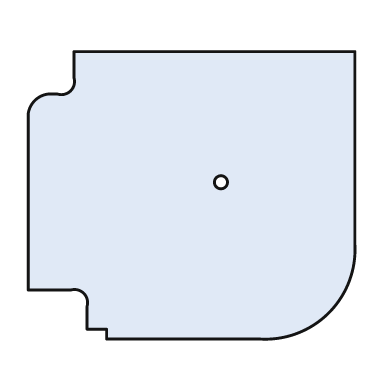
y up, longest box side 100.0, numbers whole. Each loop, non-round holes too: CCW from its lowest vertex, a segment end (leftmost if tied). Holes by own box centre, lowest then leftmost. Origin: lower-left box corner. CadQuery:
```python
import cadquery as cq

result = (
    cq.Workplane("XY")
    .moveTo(24.0, 0.0)
    .lineTo(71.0, 0.0)
    .threePointArc((92.0, 8.0), (100.0, 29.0))
    .lineTo(100.0, 88.0)
    .lineTo(14.0, 88.0)
    .lineTo(14.0, 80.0)
    .threePointArc((13.0, 76.0), (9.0, 75.0))
    .lineTo(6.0, 75.0)
    .threePointArc((2.0, 73.0), (0.0, 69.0))
    .lineTo(0.0, 15.0)
    .lineTo(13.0, 15.0)
    .threePointArc((17.0, 14.0), (18.0, 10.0))
    .lineTo(18.0, 3.0)
    .lineTo(24.0, 3.0)
    .close()
    .moveTo(59.0, 48.0)
    .circle(2.0)
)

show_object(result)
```